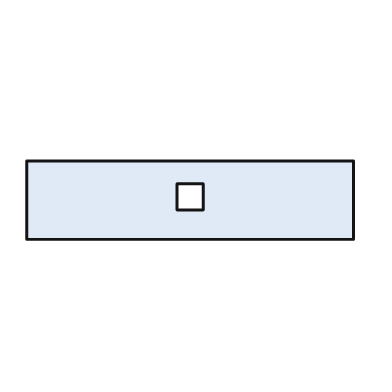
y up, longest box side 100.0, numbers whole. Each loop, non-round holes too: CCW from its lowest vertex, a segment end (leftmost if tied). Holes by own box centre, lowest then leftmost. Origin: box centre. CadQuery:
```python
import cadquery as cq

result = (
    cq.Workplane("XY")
    .moveTo(-50.0, -12.0)
    .lineTo(50.0, -12.0)
    .lineTo(50.0, 12.0)
    .lineTo(-50.0, 12.0)
    .close()
    .moveTo(-4.0, -3.0)
    .lineTo(4.0, -3.0)
    .lineTo(4.0, 5.0)
    .lineTo(-4.0, 5.0)
    .close()
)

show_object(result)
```